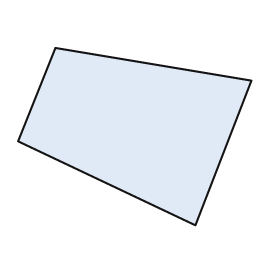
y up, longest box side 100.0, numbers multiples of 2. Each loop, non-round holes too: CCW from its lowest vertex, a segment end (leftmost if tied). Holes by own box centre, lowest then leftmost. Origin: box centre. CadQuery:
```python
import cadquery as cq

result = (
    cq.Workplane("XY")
    .moveTo(26.0, -38.0)
    .lineTo(50.0, 24.0)
    .lineTo(-34.0, 38.0)
    .lineTo(-50.0, -2.0)
    .close()
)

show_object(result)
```